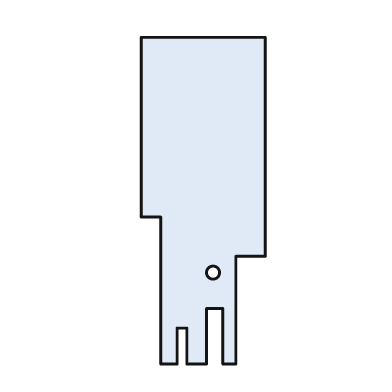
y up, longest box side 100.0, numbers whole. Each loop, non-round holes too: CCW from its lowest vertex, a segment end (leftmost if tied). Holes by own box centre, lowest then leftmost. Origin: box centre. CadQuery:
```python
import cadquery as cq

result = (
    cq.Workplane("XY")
    .moveTo(-13.0, -50.0)
    .lineTo(-8.0, -50.0)
    .lineTo(-8.0, -39.0)
    .lineTo(-5.0, -39.0)
    .lineTo(-5.0, -50.0)
    .lineTo(1.0, -50.0)
    .lineTo(1.0, -33.0)
    .lineTo(6.0, -33.0)
    .lineTo(6.0, -50.0)
    .lineTo(10.0, -50.0)
    .lineTo(10.0, -17.0)
    .lineTo(19.0, -17.0)
    .lineTo(19.0, 50.0)
    .lineTo(-19.0, 50.0)
    .lineTo(-19.0, -5.0)
    .lineTo(-13.0, -5.0)
    .close()
    .moveTo(3.0, -22.0)
    .circle(2.0)
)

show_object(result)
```